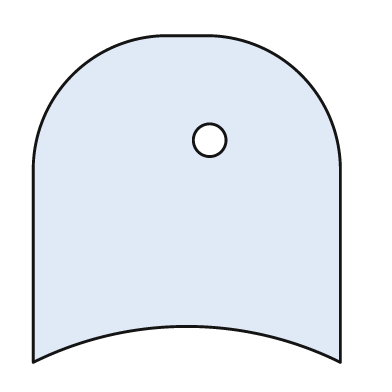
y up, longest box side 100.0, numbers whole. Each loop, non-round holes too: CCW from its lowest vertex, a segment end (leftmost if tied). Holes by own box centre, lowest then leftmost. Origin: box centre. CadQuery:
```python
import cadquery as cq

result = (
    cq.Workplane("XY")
    .moveTo(-47.0, -50.0)
    .threePointArc((0.0, -39.0), (47.0, -50.0))
    .lineTo(47.0, 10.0)
    .threePointArc((35.0, 38.0), (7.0, 50.0))
    .lineTo(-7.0, 50.0)
    .threePointArc((-35.0, 38.0), (-47.0, 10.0))
    .close()
    .moveTo(7.0, 18.0)
    .circle(5.0)
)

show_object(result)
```